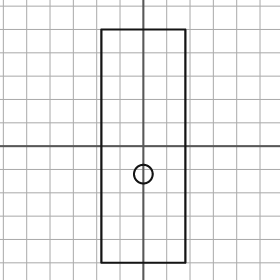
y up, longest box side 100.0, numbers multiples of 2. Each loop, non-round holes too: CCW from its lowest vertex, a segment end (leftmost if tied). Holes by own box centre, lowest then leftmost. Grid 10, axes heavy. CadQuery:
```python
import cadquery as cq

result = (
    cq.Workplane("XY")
    .moveTo(-18.0, -50.0)
    .lineTo(18.0, -50.0)
    .lineTo(18.0, 50.0)
    .lineTo(-18.0, 50.0)
    .close()
    .moveTo(0.0, -12.0)
    .circle(4.0)
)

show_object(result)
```